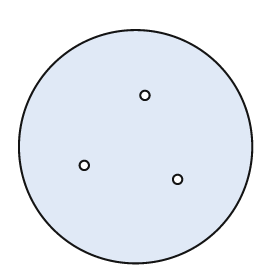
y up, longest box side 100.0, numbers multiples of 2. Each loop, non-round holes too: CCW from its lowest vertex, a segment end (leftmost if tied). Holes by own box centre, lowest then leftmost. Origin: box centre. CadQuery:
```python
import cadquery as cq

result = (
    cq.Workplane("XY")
    .moveTo(0.0, 0.0)
    .circle(50.0)
    .moveTo(18.0, -14.0)
    .circle(2.0)
    .moveTo(-22.0, -8.0)
    .circle(2.0)
    .moveTo(4.0, 22.0)
    .circle(2.0)
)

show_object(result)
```